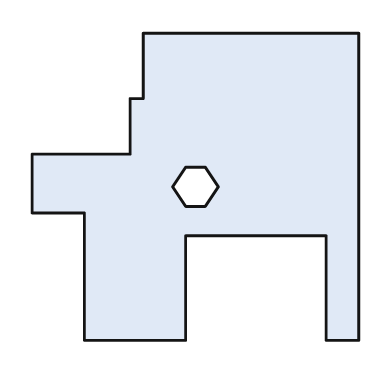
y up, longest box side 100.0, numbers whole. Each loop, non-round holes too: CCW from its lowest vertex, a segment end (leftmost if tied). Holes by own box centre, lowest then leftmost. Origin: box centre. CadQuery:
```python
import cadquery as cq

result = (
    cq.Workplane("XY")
    .moveTo(-34.0, -47.0)
    .lineTo(-3.0, -47.0)
    .lineTo(-3.0, -15.0)
    .lineTo(40.0, -15.0)
    .lineTo(40.0, -47.0)
    .lineTo(50.0, -47.0)
    .lineTo(50.0, 47.0)
    .lineTo(-16.0, 47.0)
    .lineTo(-16.0, 27.0)
    .lineTo(-20.0, 27.0)
    .lineTo(-20.0, 10.0)
    .lineTo(-50.0, 10.0)
    .lineTo(-50.0, -8.0)
    .lineTo(-34.0, -8.0)
    .close()
    .moveTo(-3.0, -6.0)
    .lineTo(3.0, -6.0)
    .lineTo(7.0, 0.0)
    .lineTo(3.0, 6.0)
    .lineTo(-3.0, 6.0)
    .lineTo(-7.0, 0.0)
    .close()
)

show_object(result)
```